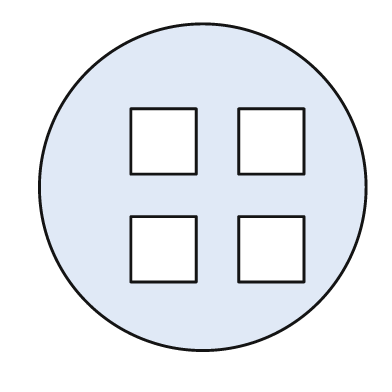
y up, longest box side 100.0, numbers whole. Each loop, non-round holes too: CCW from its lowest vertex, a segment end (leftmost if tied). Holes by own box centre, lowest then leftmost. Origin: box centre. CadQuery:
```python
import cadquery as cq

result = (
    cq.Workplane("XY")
    .moveTo(0.0, 0.0)
    .circle(50.0)
    .moveTo(-22.0, -29.0)
    .lineTo(-2.0, -29.0)
    .lineTo(-2.0, -9.0)
    .lineTo(-22.0, -9.0)
    .close()
    .moveTo(11.0, -29.0)
    .lineTo(31.0, -29.0)
    .lineTo(31.0, -9.0)
    .lineTo(11.0, -9.0)
    .close()
    .moveTo(-22.0, 4.0)
    .lineTo(-2.0, 4.0)
    .lineTo(-2.0, 24.0)
    .lineTo(-22.0, 24.0)
    .close()
    .moveTo(11.0, 4.0)
    .lineTo(31.0, 4.0)
    .lineTo(31.0, 24.0)
    .lineTo(11.0, 24.0)
    .close()
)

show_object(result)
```